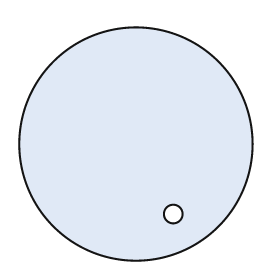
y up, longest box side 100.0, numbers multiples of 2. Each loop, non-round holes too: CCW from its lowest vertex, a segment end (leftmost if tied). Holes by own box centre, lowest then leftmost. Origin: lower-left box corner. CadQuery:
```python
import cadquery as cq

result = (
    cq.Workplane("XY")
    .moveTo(50.0, 50.0)
    .circle(50.0)
    .moveTo(66.0, 20.0)
    .circle(4.0)
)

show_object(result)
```